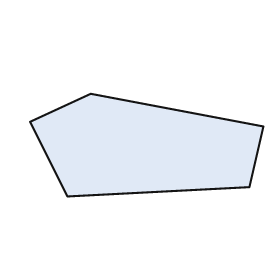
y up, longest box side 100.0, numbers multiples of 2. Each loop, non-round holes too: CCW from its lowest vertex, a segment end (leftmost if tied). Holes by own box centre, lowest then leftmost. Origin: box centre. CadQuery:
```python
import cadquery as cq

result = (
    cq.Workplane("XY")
    .moveTo(-34.0, -22.0)
    .lineTo(44.0, -18.0)
    .lineTo(50.0, 8.0)
    .lineTo(-24.0, 22.0)
    .lineTo(-50.0, 10.0)
    .close()
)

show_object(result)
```